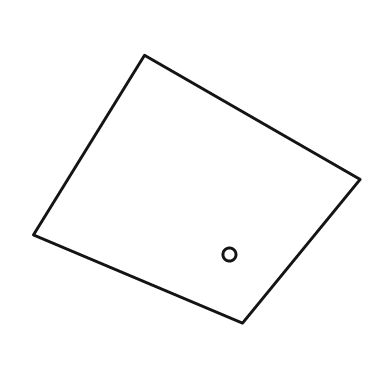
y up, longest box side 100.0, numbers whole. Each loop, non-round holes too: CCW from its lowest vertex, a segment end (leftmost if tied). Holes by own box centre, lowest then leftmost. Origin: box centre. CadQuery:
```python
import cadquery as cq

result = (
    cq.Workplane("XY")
    .moveTo(14.0, -41.0)
    .lineTo(50.0, 3.0)
    .lineTo(-16.0, 41.0)
    .lineTo(-50.0, -14.0)
    .close()
    .moveTo(10.0, -20.0)
    .circle(2.0)
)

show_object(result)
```